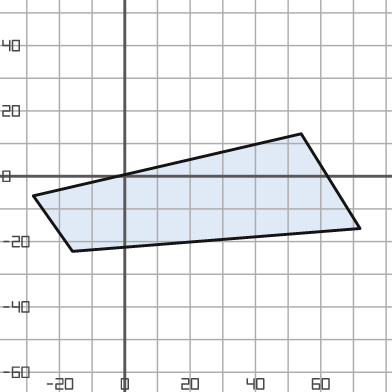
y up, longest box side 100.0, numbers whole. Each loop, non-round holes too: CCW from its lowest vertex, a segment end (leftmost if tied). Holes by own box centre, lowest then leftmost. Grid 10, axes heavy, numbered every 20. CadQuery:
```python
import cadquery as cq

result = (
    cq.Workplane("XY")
    .moveTo(-16.0, -23.0)
    .lineTo(72.0, -16.0)
    .lineTo(54.0, 13.0)
    .lineTo(-28.0, -6.0)
    .close()
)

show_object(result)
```